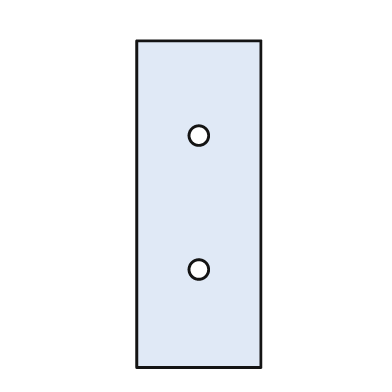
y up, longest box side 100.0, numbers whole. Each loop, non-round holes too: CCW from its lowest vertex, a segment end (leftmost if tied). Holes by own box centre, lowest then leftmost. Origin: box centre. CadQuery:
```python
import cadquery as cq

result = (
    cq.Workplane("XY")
    .moveTo(-19.0, -50.0)
    .lineTo(19.0, -50.0)
    .lineTo(19.0, 50.0)
    .lineTo(-19.0, 50.0)
    .close()
    .moveTo(0.0, -20.0)
    .circle(3.0)
    .moveTo(0.0, 21.0)
    .circle(3.0)
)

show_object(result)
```